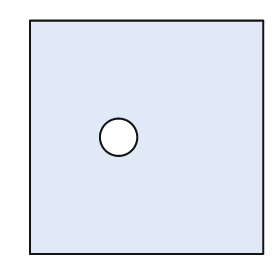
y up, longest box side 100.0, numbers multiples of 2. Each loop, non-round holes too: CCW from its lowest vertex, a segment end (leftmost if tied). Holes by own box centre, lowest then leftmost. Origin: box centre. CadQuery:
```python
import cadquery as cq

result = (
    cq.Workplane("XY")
    .moveTo(-50.0, -50.0)
    .lineTo(50.0, -50.0)
    .lineTo(50.0, 50.0)
    .lineTo(-50.0, 50.0)
    .close()
    .moveTo(-12.0, 0.0)
    .circle(8.0)
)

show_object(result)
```